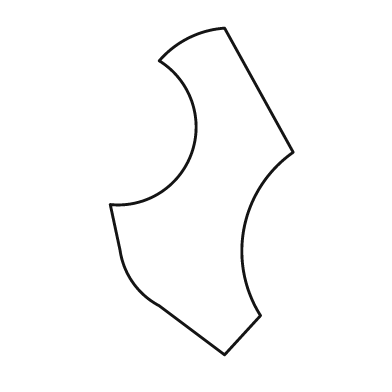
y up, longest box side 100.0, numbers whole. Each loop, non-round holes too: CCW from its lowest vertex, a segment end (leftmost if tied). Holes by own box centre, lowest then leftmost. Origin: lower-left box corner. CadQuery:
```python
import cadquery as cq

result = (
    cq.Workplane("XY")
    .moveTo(35.0, 0.0)
    .lineTo(46.0, 12.0)
    .threePointArc((41.0, 39.0), (56.0, 62.0))
    .lineTo(35.0, 100.0)
    .threePointArc((24.0, 97.0), (15.0, 90.0))
    .threePointArc((25.0, 62.0), (0.0, 46.0))
    .lineTo(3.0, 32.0)
    .threePointArc((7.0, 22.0), (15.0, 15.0))
    .close()
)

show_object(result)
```